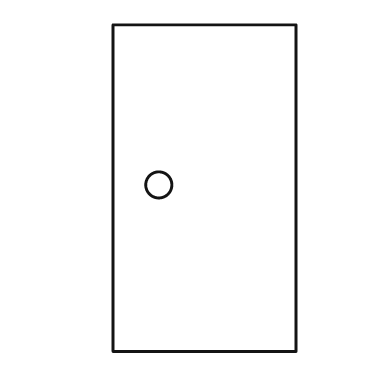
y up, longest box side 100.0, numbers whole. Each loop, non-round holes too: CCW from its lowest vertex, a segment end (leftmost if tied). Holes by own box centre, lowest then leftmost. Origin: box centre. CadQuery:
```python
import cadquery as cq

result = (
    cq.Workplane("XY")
    .moveTo(-28.0, -50.0)
    .lineTo(28.0, -50.0)
    .lineTo(28.0, 50.0)
    .lineTo(-28.0, 50.0)
    .close()
    .moveTo(-14.0, 1.0)
    .circle(4.0)
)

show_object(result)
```